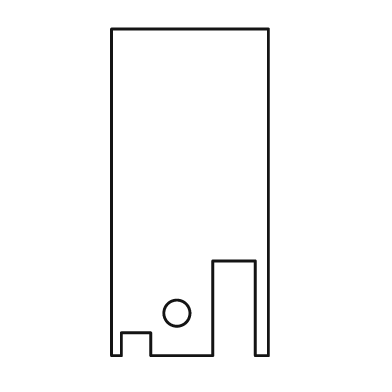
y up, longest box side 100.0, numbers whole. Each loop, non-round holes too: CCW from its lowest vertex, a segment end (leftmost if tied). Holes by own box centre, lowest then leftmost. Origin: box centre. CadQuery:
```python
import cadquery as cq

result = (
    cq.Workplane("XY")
    .moveTo(-24.0, -50.0)
    .lineTo(-21.0, -50.0)
    .lineTo(-21.0, -43.0)
    .lineTo(-12.0, -43.0)
    .lineTo(-12.0, -50.0)
    .lineTo(7.0, -50.0)
    .lineTo(7.0, -21.0)
    .lineTo(20.0, -21.0)
    .lineTo(20.0, -50.0)
    .lineTo(24.0, -50.0)
    .lineTo(24.0, 50.0)
    .lineTo(-24.0, 50.0)
    .close()
    .moveTo(-4.0, -37.0)
    .circle(4.0)
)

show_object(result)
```